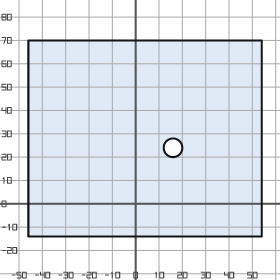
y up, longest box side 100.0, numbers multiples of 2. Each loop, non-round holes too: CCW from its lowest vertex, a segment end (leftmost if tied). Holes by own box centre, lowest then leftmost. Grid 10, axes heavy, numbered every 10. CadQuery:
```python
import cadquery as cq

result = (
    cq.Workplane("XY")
    .moveTo(-46.0, -14.0)
    .lineTo(54.0, -14.0)
    .lineTo(54.0, 70.0)
    .lineTo(-46.0, 70.0)
    .close()
    .moveTo(16.0, 24.0)
    .circle(4.0)
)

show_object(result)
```